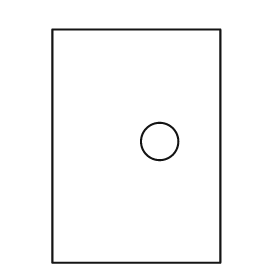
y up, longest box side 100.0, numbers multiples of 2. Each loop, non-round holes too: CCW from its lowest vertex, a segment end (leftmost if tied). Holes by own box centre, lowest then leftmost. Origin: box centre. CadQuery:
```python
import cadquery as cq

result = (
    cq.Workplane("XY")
    .moveTo(-36.0, -50.0)
    .lineTo(36.0, -50.0)
    .lineTo(36.0, 50.0)
    .lineTo(-36.0, 50.0)
    .close()
    .moveTo(10.0, 2.0)
    .circle(8.0)
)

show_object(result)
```